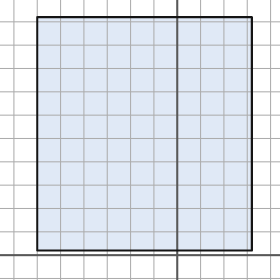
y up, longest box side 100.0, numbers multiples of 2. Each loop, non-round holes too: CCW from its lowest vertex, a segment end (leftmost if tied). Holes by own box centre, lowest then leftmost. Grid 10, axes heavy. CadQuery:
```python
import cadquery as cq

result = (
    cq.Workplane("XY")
    .moveTo(-60.0, 2.0)
    .lineTo(32.0, 2.0)
    .lineTo(32.0, 102.0)
    .lineTo(-60.0, 102.0)
    .close()
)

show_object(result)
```